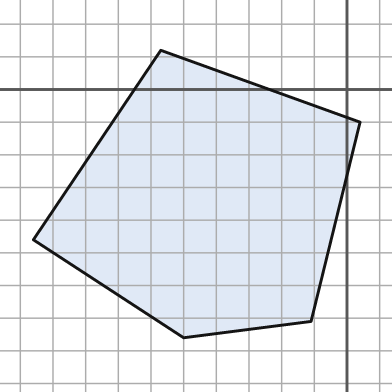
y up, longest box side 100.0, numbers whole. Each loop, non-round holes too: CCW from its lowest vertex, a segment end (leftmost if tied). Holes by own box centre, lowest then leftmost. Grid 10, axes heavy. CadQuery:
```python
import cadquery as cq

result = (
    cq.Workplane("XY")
    .moveTo(-50.0, -76.0)
    .lineTo(-11.0, -71.0)
    .lineTo(4.0, -10.0)
    .lineTo(-57.0, 12.0)
    .lineTo(-96.0, -46.0)
    .close()
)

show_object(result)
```